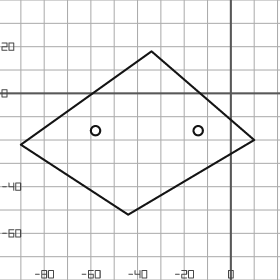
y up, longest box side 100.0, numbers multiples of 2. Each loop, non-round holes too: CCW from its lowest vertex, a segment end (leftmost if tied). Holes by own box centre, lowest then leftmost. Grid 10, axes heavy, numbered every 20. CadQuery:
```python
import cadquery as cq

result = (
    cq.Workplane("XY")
    .moveTo(-44.0, -52.0)
    .lineTo(10.0, -20.0)
    .lineTo(-34.0, 18.0)
    .lineTo(-90.0, -22.0)
    .close()
    .moveTo(-58.0, -16.0)
    .circle(2.0)
    .moveTo(-14.0, -16.0)
    .circle(2.0)
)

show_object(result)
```